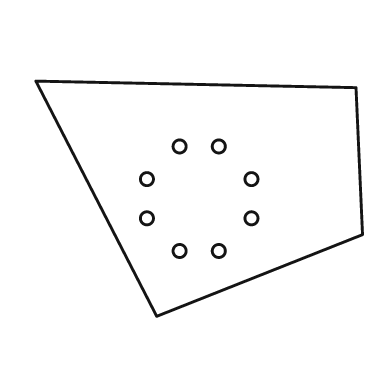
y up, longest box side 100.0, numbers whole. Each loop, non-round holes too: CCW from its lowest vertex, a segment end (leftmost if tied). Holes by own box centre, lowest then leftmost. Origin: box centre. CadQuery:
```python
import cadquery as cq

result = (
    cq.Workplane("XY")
    .moveTo(-13.0, -36.0)
    .lineTo(50.0, -11.0)
    .lineTo(48.0, 34.0)
    .lineTo(-50.0, 36.0)
    .close()
    .moveTo(-6.0, -16.0)
    .circle(2.0)
    .moveTo(6.0, -16.0)
    .circle(2.0)
    .moveTo(-16.0, -6.0)
    .circle(2.0)
    .moveTo(16.0, -6.0)
    .circle(2.0)
    .moveTo(-16.0, 6.0)
    .circle(2.0)
    .moveTo(16.0, 6.0)
    .circle(2.0)
    .moveTo(-6.0, 16.0)
    .circle(2.0)
    .moveTo(6.0, 16.0)
    .circle(2.0)
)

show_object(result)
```